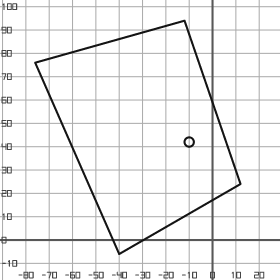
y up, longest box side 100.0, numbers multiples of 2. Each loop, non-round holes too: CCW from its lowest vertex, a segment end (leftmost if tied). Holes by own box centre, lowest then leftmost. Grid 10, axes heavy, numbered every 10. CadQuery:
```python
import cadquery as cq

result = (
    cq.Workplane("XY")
    .moveTo(-40.0, -6.0)
    .lineTo(12.0, 24.0)
    .lineTo(-12.0, 94.0)
    .lineTo(-76.0, 76.0)
    .close()
    .moveTo(-10.0, 42.0)
    .circle(2.0)
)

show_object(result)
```